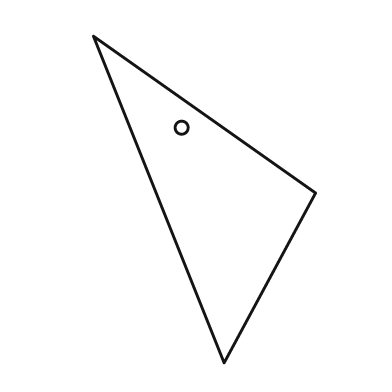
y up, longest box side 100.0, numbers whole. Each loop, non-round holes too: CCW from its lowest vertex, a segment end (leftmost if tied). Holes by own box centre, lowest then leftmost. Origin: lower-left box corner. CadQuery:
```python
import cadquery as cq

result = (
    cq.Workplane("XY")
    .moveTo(40.0, 0.0)
    .lineTo(68.0, 52.0)
    .lineTo(0.0, 100.0)
    .close()
    .moveTo(27.0, 72.0)
    .circle(2.0)
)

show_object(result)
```